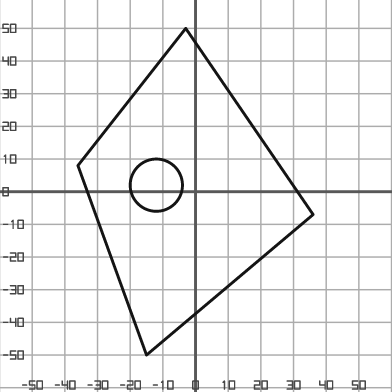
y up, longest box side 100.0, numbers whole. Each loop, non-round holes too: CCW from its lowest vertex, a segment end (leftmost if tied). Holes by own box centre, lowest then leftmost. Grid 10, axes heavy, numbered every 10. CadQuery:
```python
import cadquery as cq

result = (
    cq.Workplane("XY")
    .moveTo(-15.0, -50.0)
    .lineTo(36.0, -7.0)
    .lineTo(-3.0, 50.0)
    .lineTo(-36.0, 8.0)
    .close()
    .moveTo(-12.0, 2.0)
    .circle(8.0)
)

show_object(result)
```